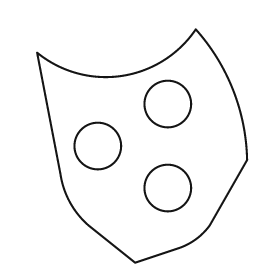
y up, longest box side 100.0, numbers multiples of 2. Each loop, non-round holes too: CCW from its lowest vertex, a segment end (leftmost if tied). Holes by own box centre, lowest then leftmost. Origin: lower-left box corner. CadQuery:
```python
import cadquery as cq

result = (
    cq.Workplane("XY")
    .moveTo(42.0, 0.0)
    .lineTo(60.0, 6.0)
    .threePointArc((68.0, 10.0), (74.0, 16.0))
    .lineTo(90.0, 44.0)
    .threePointArc((84.0, 74.0), (68.0, 100.0))
    .threePointArc((36.0, 80.0), (0.0, 90.0))
    .lineTo(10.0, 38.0)
    .threePointArc((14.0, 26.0), (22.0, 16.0))
    .close()
    .moveTo(56.0, 32.0)
    .circle(10.0)
    .moveTo(26.0, 50.0)
    .circle(10.0)
    .moveTo(56.0, 68.0)
    .circle(10.0)
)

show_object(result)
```